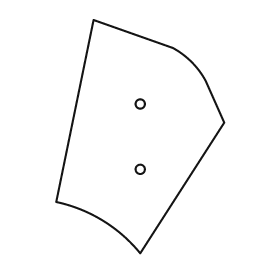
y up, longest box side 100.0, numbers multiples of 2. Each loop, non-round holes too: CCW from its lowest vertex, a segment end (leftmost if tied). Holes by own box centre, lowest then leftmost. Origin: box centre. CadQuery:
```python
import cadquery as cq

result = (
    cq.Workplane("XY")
    .moveTo(0.0, -50.0)
    .lineTo(36.0, 6.0)
    .lineTo(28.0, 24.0)
    .threePointArc((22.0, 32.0), (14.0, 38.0))
    .lineTo(-20.0, 50.0)
    .lineTo(-36.0, -28.0)
    .threePointArc((-16.0, -36.0), (0.0, -50.0))
    .close()
    .moveTo(0.0, -14.0)
    .circle(2.0)
    .moveTo(0.0, 14.0)
    .circle(2.0)
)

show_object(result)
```